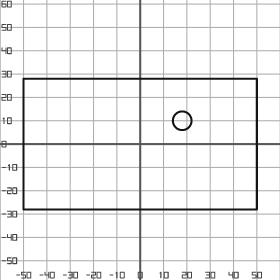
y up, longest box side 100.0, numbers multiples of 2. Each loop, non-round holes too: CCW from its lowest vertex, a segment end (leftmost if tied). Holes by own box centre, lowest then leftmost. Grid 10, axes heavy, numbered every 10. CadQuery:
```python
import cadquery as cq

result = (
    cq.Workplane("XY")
    .moveTo(-50.0, -28.0)
    .lineTo(50.0, -28.0)
    .lineTo(50.0, 28.0)
    .lineTo(-50.0, 28.0)
    .close()
    .moveTo(18.0, 10.0)
    .circle(4.0)
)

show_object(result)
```